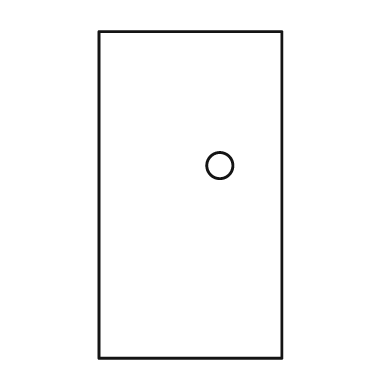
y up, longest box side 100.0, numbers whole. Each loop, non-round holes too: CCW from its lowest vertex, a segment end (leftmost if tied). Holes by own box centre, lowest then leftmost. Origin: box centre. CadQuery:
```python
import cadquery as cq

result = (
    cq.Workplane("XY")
    .moveTo(-28.0, -50.0)
    .lineTo(28.0, -50.0)
    .lineTo(28.0, 50.0)
    .lineTo(-28.0, 50.0)
    .close()
    .moveTo(9.0, 9.0)
    .circle(4.0)
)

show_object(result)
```